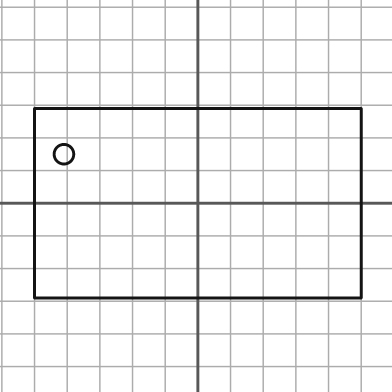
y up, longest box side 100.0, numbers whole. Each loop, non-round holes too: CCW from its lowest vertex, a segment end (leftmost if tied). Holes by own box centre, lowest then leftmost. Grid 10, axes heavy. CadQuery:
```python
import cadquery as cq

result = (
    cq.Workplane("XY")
    .moveTo(-50.0, -29.0)
    .lineTo(50.0, -29.0)
    .lineTo(50.0, 29.0)
    .lineTo(-50.0, 29.0)
    .close()
    .moveTo(-41.0, 15.0)
    .circle(3.0)
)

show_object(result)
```